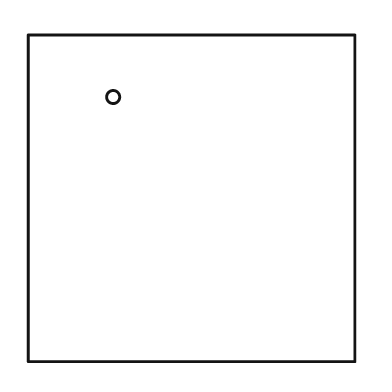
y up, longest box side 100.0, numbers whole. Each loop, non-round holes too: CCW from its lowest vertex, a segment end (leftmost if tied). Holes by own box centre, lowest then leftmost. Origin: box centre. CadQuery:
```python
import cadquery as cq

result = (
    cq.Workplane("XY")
    .moveTo(-50.0, -50.0)
    .lineTo(50.0, -50.0)
    .lineTo(50.0, 50.0)
    .lineTo(-50.0, 50.0)
    .close()
    .moveTo(-24.0, 31.0)
    .circle(2.0)
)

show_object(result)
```